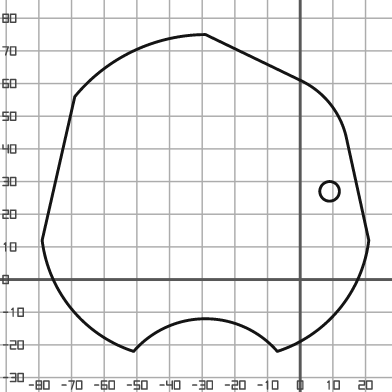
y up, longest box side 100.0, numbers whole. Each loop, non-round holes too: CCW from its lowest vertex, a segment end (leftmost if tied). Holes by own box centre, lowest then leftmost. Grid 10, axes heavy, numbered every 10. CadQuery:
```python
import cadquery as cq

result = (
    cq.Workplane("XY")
    .moveTo(-51.0, -22.0)
    .threePointArc((-29.0, -12.0), (-7.0, -22.0))
    .threePointArc((12.0, -9.0), (21.0, 12.0))
    .lineTo(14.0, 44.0)
    .threePointArc((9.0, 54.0), (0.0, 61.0))
    .lineTo(-29.0, 75.0)
    .threePointArc((-51.0, 70.0), (-69.0, 56.0))
    .lineTo(-79.0, 12.0)
    .threePointArc((-70.0, -9.0), (-51.0, -22.0))
    .close()
    .moveTo(9.0, 27.0)
    .circle(3.0)
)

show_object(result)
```